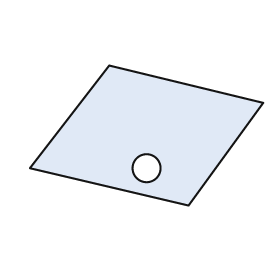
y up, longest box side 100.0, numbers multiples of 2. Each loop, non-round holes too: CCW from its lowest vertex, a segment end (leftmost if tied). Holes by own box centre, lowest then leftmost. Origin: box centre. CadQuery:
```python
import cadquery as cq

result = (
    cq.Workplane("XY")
    .moveTo(18.0, -30.0)
    .lineTo(50.0, 14.0)
    .lineTo(-16.0, 30.0)
    .lineTo(-50.0, -14.0)
    .close()
    .moveTo(0.0, -14.0)
    .circle(6.0)
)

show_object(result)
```